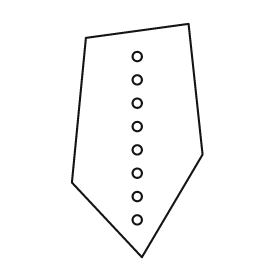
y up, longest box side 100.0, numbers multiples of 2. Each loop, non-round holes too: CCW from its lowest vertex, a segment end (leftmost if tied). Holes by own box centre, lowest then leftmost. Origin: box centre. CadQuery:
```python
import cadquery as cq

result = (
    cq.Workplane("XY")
    .moveTo(2.0, -50.0)
    .lineTo(28.0, -6.0)
    .lineTo(22.0, 50.0)
    .lineTo(-22.0, 44.0)
    .lineTo(-28.0, -18.0)
    .close()
    .moveTo(0.0, -34.0)
    .circle(2.0)
    .moveTo(0.0, -24.0)
    .circle(2.0)
    .moveTo(0.0, -14.0)
    .circle(2.0)
    .moveTo(0.0, -4.0)
    .circle(2.0)
    .moveTo(0.0, 6.0)
    .circle(2.0)
    .moveTo(0.0, 16.0)
    .circle(2.0)
    .moveTo(0.0, 26.0)
    .circle(2.0)
    .moveTo(0.0, 36.0)
    .circle(2.0)
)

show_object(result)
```